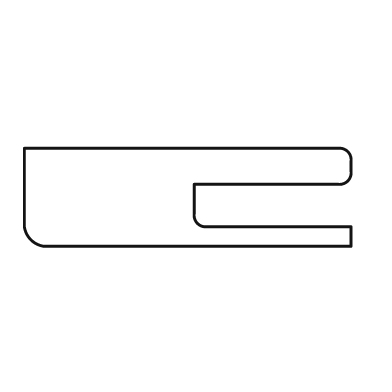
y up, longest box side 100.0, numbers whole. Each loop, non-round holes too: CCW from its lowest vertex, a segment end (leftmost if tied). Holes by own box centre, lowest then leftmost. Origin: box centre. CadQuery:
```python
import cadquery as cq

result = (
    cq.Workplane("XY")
    .moveTo(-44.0, -15.0)
    .lineTo(50.0, -15.0)
    .lineTo(50.0, -9.0)
    .lineTo(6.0, -9.0)
    .threePointArc((3.0, -8.0), (2.0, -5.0))
    .lineTo(2.0, 4.0)
    .lineTo(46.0, 4.0)
    .threePointArc((49.0, 5.0), (50.0, 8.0))
    .lineTo(50.0, 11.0)
    .threePointArc((49.0, 14.0), (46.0, 15.0))
    .lineTo(-50.0, 15.0)
    .lineTo(-50.0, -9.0)
    .threePointArc((-48.0, -13.0), (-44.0, -15.0))
    .close()
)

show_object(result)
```